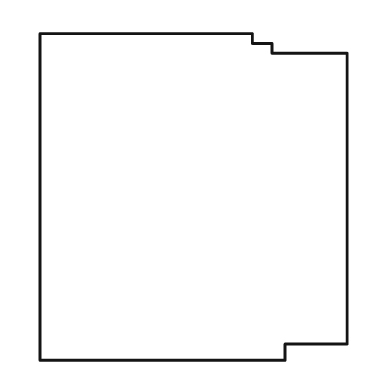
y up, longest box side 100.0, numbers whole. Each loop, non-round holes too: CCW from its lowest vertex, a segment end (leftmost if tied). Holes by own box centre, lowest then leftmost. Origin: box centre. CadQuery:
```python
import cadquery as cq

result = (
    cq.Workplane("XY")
    .moveTo(-47.0, -50.0)
    .lineTo(28.0, -50.0)
    .lineTo(28.0, -45.0)
    .lineTo(47.0, -45.0)
    .lineTo(47.0, 44.0)
    .lineTo(24.0, 44.0)
    .lineTo(24.0, 47.0)
    .lineTo(18.0, 47.0)
    .lineTo(18.0, 50.0)
    .lineTo(-47.0, 50.0)
    .close()
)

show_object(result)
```